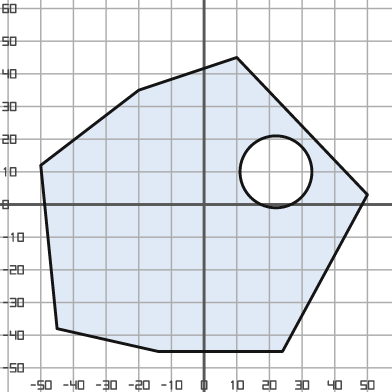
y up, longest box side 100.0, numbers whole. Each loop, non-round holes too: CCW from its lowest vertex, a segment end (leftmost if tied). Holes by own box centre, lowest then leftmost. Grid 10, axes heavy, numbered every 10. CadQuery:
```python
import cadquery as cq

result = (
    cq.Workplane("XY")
    .moveTo(-14.0, -45.0)
    .lineTo(24.0, -45.0)
    .lineTo(50.0, 3.0)
    .lineTo(10.0, 45.0)
    .lineTo(-20.0, 35.0)
    .lineTo(-50.0, 12.0)
    .lineTo(-45.0, -38.0)
    .close()
    .moveTo(22.0, 10.0)
    .circle(11.0)
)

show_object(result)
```